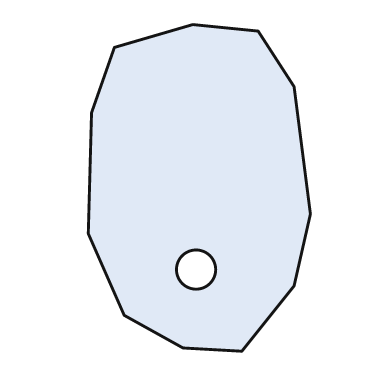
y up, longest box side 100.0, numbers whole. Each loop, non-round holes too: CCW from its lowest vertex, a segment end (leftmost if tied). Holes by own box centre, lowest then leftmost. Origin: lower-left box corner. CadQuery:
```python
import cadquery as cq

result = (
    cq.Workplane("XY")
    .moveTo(47.0, 0.0)
    .lineTo(63.0, 20.0)
    .lineTo(68.0, 42.0)
    .lineTo(63.0, 81.0)
    .lineTo(52.0, 98.0)
    .lineTo(32.0, 100.0)
    .lineTo(8.0, 93.0)
    .lineTo(1.0, 73.0)
    .lineTo(0.0, 36.0)
    .lineTo(11.0, 11.0)
    .lineTo(29.0, 1.0)
    .close()
    .moveTo(33.0, 25.0)
    .circle(6.0)
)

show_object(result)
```